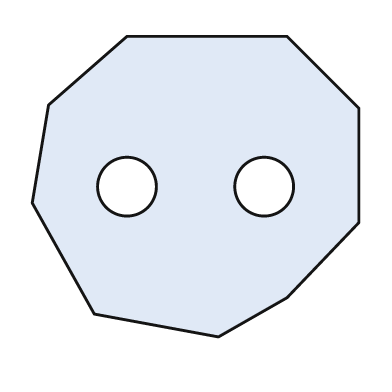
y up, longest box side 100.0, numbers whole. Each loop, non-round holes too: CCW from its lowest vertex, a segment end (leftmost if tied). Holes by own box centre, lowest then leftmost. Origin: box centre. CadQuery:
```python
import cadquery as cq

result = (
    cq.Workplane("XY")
    .moveTo(7.0, -46.0)
    .lineTo(28.0, -34.0)
    .lineTo(50.0, -11.0)
    .lineTo(50.0, 24.0)
    .lineTo(28.0, 46.0)
    .lineTo(-21.0, 46.0)
    .lineTo(-45.0, 25.0)
    .lineTo(-50.0, -5.0)
    .lineTo(-31.0, -39.0)
    .close()
    .moveTo(-21.0, 0.0)
    .circle(9.0)
    .moveTo(21.0, 0.0)
    .circle(9.0)
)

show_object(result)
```